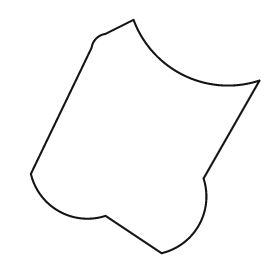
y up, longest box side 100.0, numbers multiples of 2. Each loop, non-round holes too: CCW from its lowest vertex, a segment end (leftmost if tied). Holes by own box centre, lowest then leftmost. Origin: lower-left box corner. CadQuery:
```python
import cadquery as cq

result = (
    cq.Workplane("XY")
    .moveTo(56.0, 0.0)
    .threePointArc((72.0, 12.0), (74.0, 32.0))
    .lineTo(98.0, 74.0)
    .threePointArc((66.0, 76.0), (44.0, 100.0))
    .lineTo(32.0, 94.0)
    .threePointArc((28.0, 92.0), (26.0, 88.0))
    .lineTo(0.0, 34.0)
    .threePointArc((12.0, 18.0), (32.0, 16.0))
    .close()
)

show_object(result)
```